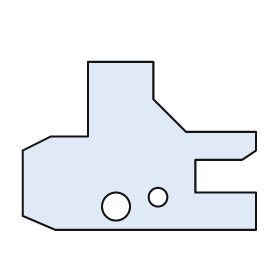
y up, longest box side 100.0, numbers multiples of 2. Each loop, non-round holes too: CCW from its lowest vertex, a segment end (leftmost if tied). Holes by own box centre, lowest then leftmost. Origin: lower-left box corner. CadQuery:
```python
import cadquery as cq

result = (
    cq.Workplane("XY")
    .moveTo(14.0, 0.0)
    .lineTo(100.0, 0.0)
    .lineTo(100.0, 16.0)
    .lineTo(74.0, 16.0)
    .lineTo(74.0, 30.0)
    .lineTo(94.0, 30.0)
    .lineTo(100.0, 34.0)
    .lineTo(100.0, 42.0)
    .lineTo(70.0, 42.0)
    .lineTo(56.0, 56.0)
    .lineTo(56.0, 72.0)
    .lineTo(28.0, 72.0)
    .lineTo(28.0, 40.0)
    .lineTo(12.0, 40.0)
    .lineTo(0.0, 34.0)
    .lineTo(0.0, 6.0)
    .close()
    .moveTo(40.0, 10.0)
    .circle(6.0)
    .moveTo(58.0, 14.0)
    .circle(4.0)
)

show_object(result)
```